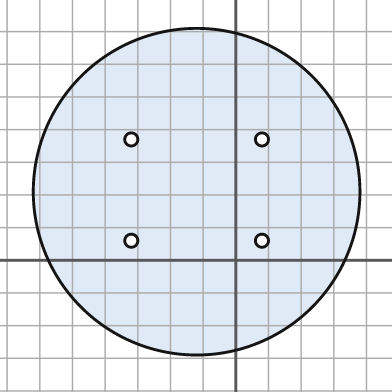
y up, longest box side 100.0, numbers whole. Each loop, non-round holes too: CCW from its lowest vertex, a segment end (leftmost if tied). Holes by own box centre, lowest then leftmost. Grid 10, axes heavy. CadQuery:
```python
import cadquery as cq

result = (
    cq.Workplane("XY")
    .moveTo(-12.0, 21.0)
    .circle(50.0)
    .moveTo(-32.0, 6.0)
    .circle(2.0)
    .moveTo(8.0, 6.0)
    .circle(2.0)
    .moveTo(-32.0, 37.0)
    .circle(2.0)
    .moveTo(8.0, 37.0)
    .circle(2.0)
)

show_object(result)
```